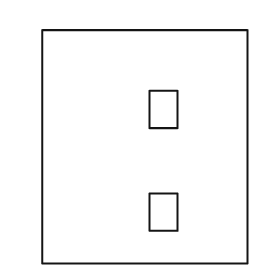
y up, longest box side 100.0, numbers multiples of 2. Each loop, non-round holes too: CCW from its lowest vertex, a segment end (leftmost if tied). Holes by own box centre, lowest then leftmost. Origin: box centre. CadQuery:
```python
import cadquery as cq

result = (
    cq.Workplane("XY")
    .moveTo(-44.0, -50.0)
    .lineTo(44.0, -50.0)
    .lineTo(44.0, 50.0)
    .lineTo(-44.0, 50.0)
    .close()
    .moveTo(2.0, -36.0)
    .lineTo(14.0, -36.0)
    .lineTo(14.0, -20.0)
    .lineTo(2.0, -20.0)
    .close()
    .moveTo(2.0, 8.0)
    .lineTo(14.0, 8.0)
    .lineTo(14.0, 24.0)
    .lineTo(2.0, 24.0)
    .close()
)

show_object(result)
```